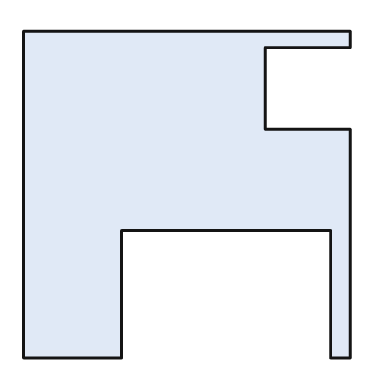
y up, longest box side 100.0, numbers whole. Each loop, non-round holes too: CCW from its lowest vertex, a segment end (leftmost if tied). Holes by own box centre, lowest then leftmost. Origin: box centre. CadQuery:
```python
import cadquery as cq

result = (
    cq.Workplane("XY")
    .moveTo(-50.0, -50.0)
    .lineTo(-20.0, -50.0)
    .lineTo(-20.0, -11.0)
    .lineTo(44.0, -11.0)
    .lineTo(44.0, -50.0)
    .lineTo(50.0, -50.0)
    .lineTo(50.0, 20.0)
    .lineTo(24.0, 20.0)
    .lineTo(24.0, 45.0)
    .lineTo(50.0, 45.0)
    .lineTo(50.0, 50.0)
    .lineTo(-50.0, 50.0)
    .close()
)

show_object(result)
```